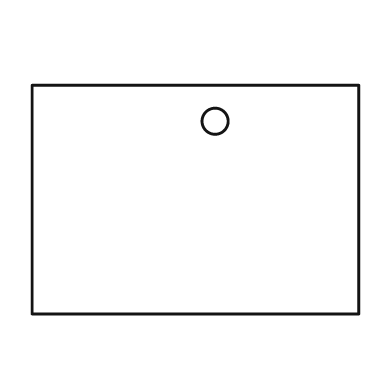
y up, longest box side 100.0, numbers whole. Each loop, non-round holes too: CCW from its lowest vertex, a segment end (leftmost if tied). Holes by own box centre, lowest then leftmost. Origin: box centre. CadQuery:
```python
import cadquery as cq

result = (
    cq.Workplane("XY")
    .moveTo(-50.0, -35.0)
    .lineTo(50.0, -35.0)
    .lineTo(50.0, 35.0)
    .lineTo(-50.0, 35.0)
    .close()
    .moveTo(6.0, 24.0)
    .circle(4.0)
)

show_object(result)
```